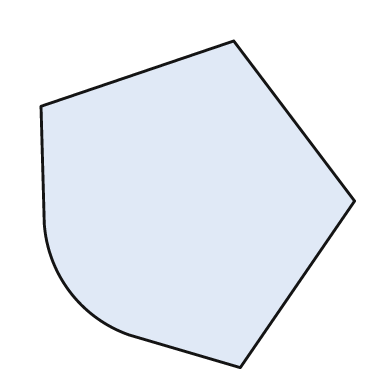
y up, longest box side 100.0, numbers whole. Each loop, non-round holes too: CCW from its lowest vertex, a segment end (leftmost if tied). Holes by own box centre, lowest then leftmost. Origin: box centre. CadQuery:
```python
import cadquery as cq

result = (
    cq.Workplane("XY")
    .moveTo(13.0, -50.0)
    .lineTo(48.0, 1.0)
    .lineTo(11.0, 50.0)
    .lineTo(-48.0, 30.0)
    .lineTo(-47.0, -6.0)
    .threePointArc((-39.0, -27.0), (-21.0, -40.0))
    .close()
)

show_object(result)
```